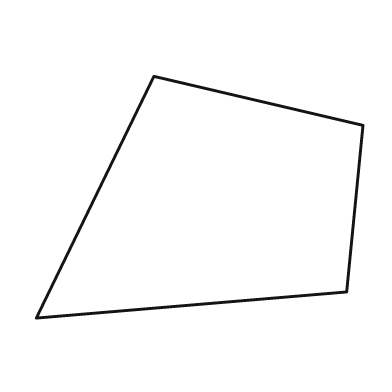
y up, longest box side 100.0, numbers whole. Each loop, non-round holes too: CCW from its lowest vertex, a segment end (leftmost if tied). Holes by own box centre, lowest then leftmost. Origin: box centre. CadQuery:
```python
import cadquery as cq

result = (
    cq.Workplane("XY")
    .moveTo(-50.0, -37.0)
    .lineTo(45.0, -29.0)
    .lineTo(50.0, 22.0)
    .lineTo(-14.0, 37.0)
    .close()
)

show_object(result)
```